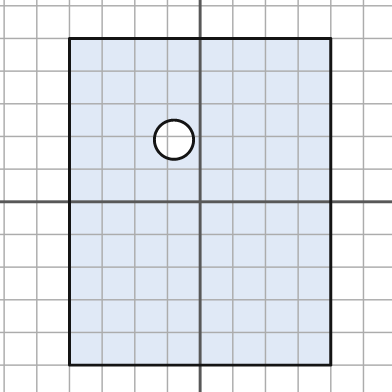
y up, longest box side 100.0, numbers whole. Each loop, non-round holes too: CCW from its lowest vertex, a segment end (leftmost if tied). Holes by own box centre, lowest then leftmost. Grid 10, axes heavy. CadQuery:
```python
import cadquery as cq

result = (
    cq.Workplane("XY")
    .moveTo(-40.0, -50.0)
    .lineTo(40.0, -50.0)
    .lineTo(40.0, 50.0)
    .lineTo(-40.0, 50.0)
    .close()
    .moveTo(-8.0, 19.0)
    .circle(6.0)
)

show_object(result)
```